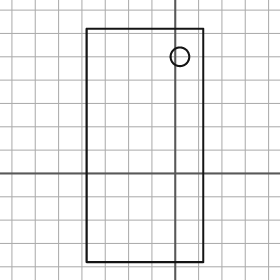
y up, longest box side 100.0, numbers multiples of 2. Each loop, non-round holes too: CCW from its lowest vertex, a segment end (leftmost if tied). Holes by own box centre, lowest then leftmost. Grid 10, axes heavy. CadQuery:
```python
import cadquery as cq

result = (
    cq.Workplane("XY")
    .moveTo(-38.0, -38.0)
    .lineTo(12.0, -38.0)
    .lineTo(12.0, 62.0)
    .lineTo(-38.0, 62.0)
    .close()
    .moveTo(2.0, 50.0)
    .circle(4.0)
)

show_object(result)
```